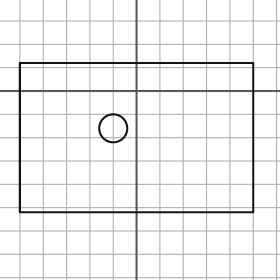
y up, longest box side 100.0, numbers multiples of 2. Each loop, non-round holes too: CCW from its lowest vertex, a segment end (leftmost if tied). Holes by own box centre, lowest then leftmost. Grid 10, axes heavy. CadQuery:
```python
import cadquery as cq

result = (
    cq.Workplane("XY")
    .moveTo(-50.0, -52.0)
    .lineTo(50.0, -52.0)
    .lineTo(50.0, 12.0)
    .lineTo(-50.0, 12.0)
    .close()
    .moveTo(-10.0, -16.0)
    .circle(6.0)
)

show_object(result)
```